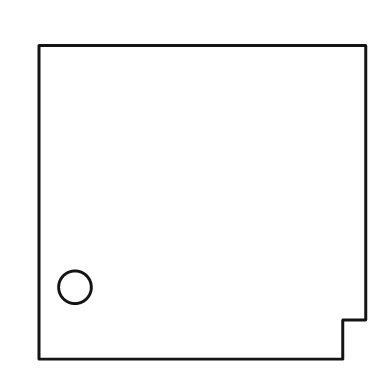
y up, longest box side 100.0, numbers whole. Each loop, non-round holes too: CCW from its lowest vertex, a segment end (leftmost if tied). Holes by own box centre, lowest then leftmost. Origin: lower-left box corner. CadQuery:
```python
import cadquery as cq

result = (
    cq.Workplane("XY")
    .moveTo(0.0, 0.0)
    .lineTo(93.0, 0.0)
    .lineTo(93.0, 12.0)
    .lineTo(100.0, 12.0)
    .lineTo(100.0, 96.0)
    .lineTo(0.0, 96.0)
    .close()
    .moveTo(11.0, 22.0)
    .circle(5.0)
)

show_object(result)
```